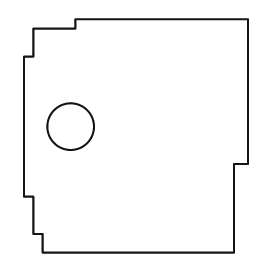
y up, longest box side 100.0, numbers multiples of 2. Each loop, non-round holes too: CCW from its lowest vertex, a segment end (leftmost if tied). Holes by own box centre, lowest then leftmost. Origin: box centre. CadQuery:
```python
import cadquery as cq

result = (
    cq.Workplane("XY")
    .moveTo(-40.0, -50.0)
    .lineTo(42.0, -50.0)
    .lineTo(42.0, -12.0)
    .lineTo(48.0, -12.0)
    .lineTo(48.0, 50.0)
    .lineTo(-26.0, 50.0)
    .lineTo(-26.0, 46.0)
    .lineTo(-44.0, 46.0)
    .lineTo(-44.0, 34.0)
    .lineTo(-48.0, 34.0)
    .lineTo(-48.0, -26.0)
    .lineTo(-44.0, -26.0)
    .lineTo(-44.0, -42.0)
    .lineTo(-40.0, -42.0)
    .close()
    .moveTo(-28.0, 4.0)
    .circle(10.0)
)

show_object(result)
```